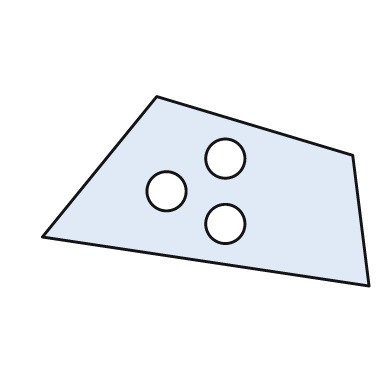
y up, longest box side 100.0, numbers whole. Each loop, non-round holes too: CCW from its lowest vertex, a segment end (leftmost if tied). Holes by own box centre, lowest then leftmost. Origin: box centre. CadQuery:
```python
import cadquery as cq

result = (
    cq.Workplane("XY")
    .moveTo(50.0, -29.0)
    .lineTo(45.0, 11.0)
    .lineTo(-15.0, 29.0)
    .lineTo(-50.0, -14.0)
    .close()
    .moveTo(6.0, -10.0)
    .circle(6.0)
    .moveTo(-12.0, 0.0)
    .circle(6.0)
    .moveTo(6.0, 10.0)
    .circle(6.0)
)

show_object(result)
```